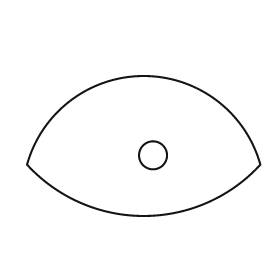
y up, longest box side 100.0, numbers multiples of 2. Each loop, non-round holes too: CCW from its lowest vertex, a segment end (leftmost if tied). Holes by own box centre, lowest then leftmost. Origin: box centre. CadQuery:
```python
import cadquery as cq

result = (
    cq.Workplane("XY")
    .moveTo(-50.0, -8.0)
    .threePointArc((0.0, -30.0), (50.0, -8.0))
    .threePointArc((0.0, 30.0), (-50.0, -8.0))
    .close()
    .moveTo(4.0, -4.0)
    .circle(6.0)
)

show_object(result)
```